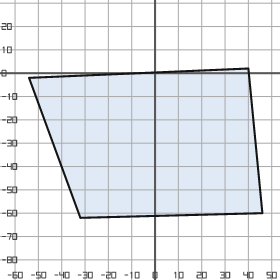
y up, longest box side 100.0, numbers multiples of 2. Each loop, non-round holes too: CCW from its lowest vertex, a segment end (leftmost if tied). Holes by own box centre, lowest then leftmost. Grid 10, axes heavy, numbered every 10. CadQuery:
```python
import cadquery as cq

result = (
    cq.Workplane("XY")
    .moveTo(-32.0, -62.0)
    .lineTo(46.0, -60.0)
    .lineTo(40.0, 2.0)
    .lineTo(-54.0, -2.0)
    .close()
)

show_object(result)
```